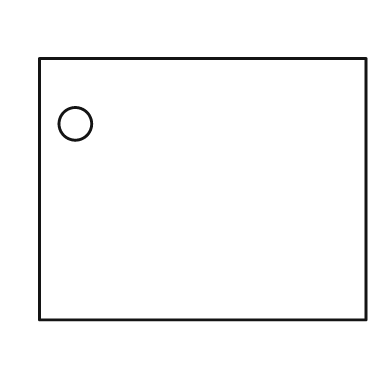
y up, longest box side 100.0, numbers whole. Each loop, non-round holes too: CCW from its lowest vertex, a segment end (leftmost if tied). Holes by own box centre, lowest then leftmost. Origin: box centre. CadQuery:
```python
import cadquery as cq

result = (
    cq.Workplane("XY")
    .moveTo(-50.0, -40.0)
    .lineTo(50.0, -40.0)
    .lineTo(50.0, 40.0)
    .lineTo(-50.0, 40.0)
    .close()
    .moveTo(-39.0, 20.0)
    .circle(5.0)
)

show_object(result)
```